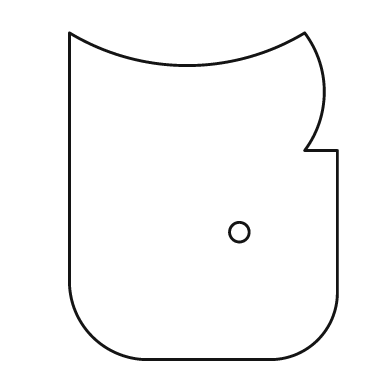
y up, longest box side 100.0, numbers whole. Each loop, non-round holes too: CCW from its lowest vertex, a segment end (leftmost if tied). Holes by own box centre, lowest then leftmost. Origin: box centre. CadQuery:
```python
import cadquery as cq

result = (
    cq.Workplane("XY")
    .moveTo(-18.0, -50.0)
    .lineTo(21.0, -50.0)
    .threePointArc((35.0, -44.0), (41.0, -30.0))
    .lineTo(41.0, 14.0)
    .lineTo(31.0, 14.0)
    .threePointArc((37.0, 32.0), (31.0, 50.0))
    .threePointArc((-5.0, 40.0), (-41.0, 50.0))
    .lineTo(-41.0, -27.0)
    .threePointArc((-34.0, -43.0), (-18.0, -50.0))
    .close()
    .moveTo(11.0, -11.0)
    .circle(3.0)
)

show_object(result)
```